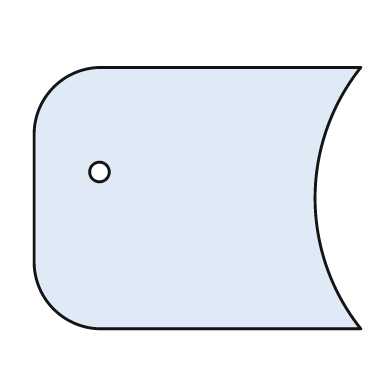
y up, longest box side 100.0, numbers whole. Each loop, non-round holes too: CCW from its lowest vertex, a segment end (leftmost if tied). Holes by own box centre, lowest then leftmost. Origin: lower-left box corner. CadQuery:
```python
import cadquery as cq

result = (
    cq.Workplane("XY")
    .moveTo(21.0, 0.0)
    .lineTo(100.0, 0.0)
    .threePointArc((86.0, 40.0), (100.0, 80.0))
    .lineTo(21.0, 80.0)
    .threePointArc((6.0, 74.0), (0.0, 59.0))
    .lineTo(0.0, 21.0)
    .threePointArc((6.0, 6.0), (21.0, 0.0))
    .close()
    .moveTo(20.0, 48.0)
    .circle(3.0)
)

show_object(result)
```